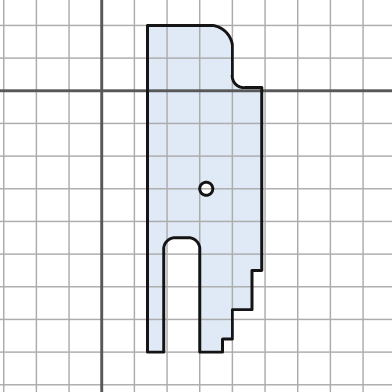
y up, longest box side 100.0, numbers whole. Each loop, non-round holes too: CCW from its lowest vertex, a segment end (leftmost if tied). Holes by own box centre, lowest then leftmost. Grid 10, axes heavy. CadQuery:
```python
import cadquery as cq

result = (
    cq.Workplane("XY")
    .moveTo(14.0, -80.0)
    .lineTo(19.0, -80.0)
    .lineTo(19.0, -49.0)
    .threePointArc((20.0, -46.0), (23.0, -45.0))
    .lineTo(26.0, -45.0)
    .threePointArc((29.0, -46.0), (30.0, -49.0))
    .lineTo(30.0, -80.0)
    .lineTo(37.0, -80.0)
    .lineTo(37.0, -76.0)
    .lineTo(40.0, -76.0)
    .lineTo(40.0, -67.0)
    .lineTo(46.0, -67.0)
    .lineTo(46.0, -55.0)
    .lineTo(49.0, -55.0)
    .lineTo(49.0, 1.0)
    .lineTo(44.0, 1.0)
    .threePointArc((41.0, 2.0), (40.0, 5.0))
    .lineTo(40.0, 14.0)
    .threePointArc((38.0, 18.0), (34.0, 20.0))
    .lineTo(14.0, 20.0)
    .close()
    .moveTo(32.0, -30.0)
    .circle(2.0)
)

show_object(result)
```